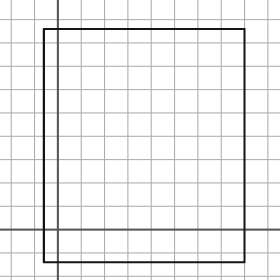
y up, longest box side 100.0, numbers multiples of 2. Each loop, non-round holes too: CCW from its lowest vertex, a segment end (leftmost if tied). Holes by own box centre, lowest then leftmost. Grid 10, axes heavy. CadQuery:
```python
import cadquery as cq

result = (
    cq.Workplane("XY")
    .moveTo(-6.0, -14.0)
    .lineTo(80.0, -14.0)
    .lineTo(80.0, 86.0)
    .lineTo(-6.0, 86.0)
    .close()
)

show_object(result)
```